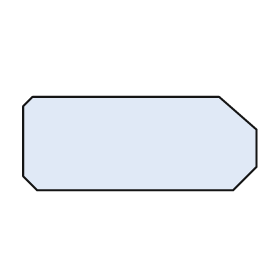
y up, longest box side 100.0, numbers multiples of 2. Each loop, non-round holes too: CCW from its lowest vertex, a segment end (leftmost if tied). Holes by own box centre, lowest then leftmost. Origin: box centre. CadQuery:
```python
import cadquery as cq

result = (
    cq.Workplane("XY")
    .moveTo(-44.0, -20.0)
    .lineTo(40.0, -20.0)
    .lineTo(50.0, -10.0)
    .lineTo(50.0, 6.0)
    .lineTo(34.0, 20.0)
    .lineTo(-46.0, 20.0)
    .lineTo(-50.0, 16.0)
    .lineTo(-50.0, -14.0)
    .close()
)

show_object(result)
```